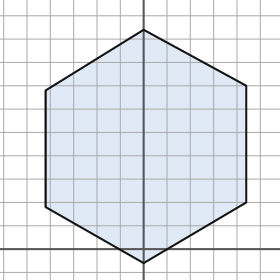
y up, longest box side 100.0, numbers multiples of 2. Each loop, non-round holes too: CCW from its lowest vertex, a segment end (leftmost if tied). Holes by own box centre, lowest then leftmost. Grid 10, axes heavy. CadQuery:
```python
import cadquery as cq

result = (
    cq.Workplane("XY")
    .moveTo(0.0, -6.0)
    .lineTo(44.0, 20.0)
    .lineTo(44.0, 70.0)
    .lineTo(0.0, 94.0)
    .lineTo(-42.0, 68.0)
    .lineTo(-42.0, 18.0)
    .close()
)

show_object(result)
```